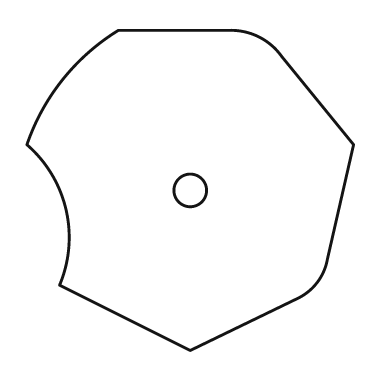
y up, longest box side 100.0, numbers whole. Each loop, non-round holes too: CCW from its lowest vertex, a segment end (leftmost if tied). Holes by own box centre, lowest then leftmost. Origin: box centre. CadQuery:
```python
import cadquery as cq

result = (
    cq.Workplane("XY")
    .moveTo(0.0, -49.0)
    .lineTo(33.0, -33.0)
    .threePointArc((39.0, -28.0), (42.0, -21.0))
    .lineTo(50.0, 14.0)
    .lineTo(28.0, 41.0)
    .threePointArc((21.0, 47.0), (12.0, 49.0))
    .lineTo(-22.0, 49.0)
    .threePointArc((-39.0, 34.0), (-50.0, 14.0))
    .threePointArc((-38.0, -6.0), (-40.0, -29.0))
    .close()
    .moveTo(0.0, 0.0)
    .circle(5.0)
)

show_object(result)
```